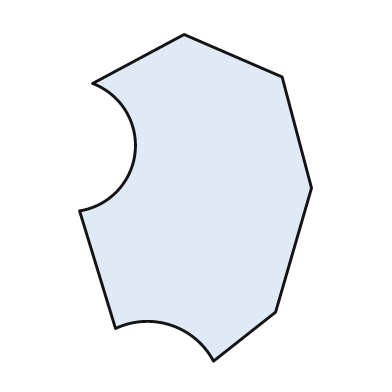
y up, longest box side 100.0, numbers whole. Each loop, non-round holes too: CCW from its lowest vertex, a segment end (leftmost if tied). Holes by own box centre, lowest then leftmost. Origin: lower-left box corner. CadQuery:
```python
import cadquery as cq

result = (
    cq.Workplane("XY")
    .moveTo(41.0, 0.0)
    .lineTo(60.0, 15.0)
    .lineTo(71.0, 53.0)
    .lineTo(62.0, 87.0)
    .lineTo(32.0, 100.0)
    .lineTo(4.0, 85.0)
    .threePointArc((17.0, 64.0), (0.0, 46.0))
    .lineTo(11.0, 10.0)
    .threePointArc((28.0, 11.0), (41.0, 0.0))
    .close()
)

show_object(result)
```